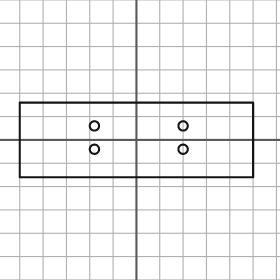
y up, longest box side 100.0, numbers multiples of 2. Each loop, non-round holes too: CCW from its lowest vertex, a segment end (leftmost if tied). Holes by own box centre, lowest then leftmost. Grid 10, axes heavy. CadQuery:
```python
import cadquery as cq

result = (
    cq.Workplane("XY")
    .moveTo(-50.0, -16.0)
    .lineTo(50.0, -16.0)
    .lineTo(50.0, 16.0)
    .lineTo(-50.0, 16.0)
    .close()
    .moveTo(-18.0, -4.0)
    .circle(2.0)
    .moveTo(20.0, -4.0)
    .circle(2.0)
    .moveTo(-18.0, 6.0)
    .circle(2.0)
    .moveTo(20.0, 6.0)
    .circle(2.0)
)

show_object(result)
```